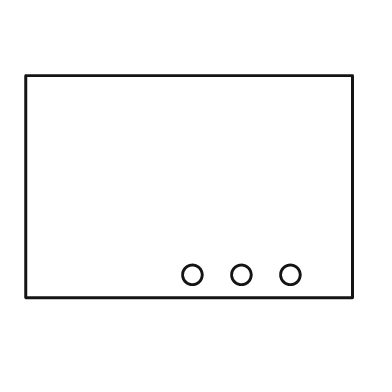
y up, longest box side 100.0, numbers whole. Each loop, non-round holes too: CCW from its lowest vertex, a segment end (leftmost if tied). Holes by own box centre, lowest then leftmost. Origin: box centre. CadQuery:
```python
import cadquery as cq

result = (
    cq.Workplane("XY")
    .moveTo(-50.0, -34.0)
    .lineTo(50.0, -34.0)
    .lineTo(50.0, 34.0)
    .lineTo(-50.0, 34.0)
    .close()
    .moveTo(1.0, -27.0)
    .circle(3.0)
    .moveTo(16.0, -27.0)
    .circle(3.0)
    .moveTo(31.0, -27.0)
    .circle(3.0)
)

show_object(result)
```